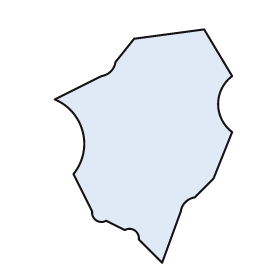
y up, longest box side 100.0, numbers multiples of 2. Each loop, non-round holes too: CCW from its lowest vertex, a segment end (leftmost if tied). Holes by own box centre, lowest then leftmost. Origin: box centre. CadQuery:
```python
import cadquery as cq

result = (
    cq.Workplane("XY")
    .moveTo(8.0, -50.0)
    .lineTo(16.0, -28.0)
    .threePointArc((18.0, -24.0), (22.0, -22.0))
    .lineTo(30.0, -14.0)
    .lineTo(38.0, 6.0)
    .threePointArc((32.0, 18.0), (38.0, 30.0))
    .lineTo(26.0, 50.0)
    .lineTo(-4.0, 46.0)
    .lineTo(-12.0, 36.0)
    .threePointArc((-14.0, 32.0), (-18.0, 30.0))
    .lineTo(-38.0, 20.0)
    .threePointArc((-26.0, 6.0), (-30.0, -12.0))
    .lineTo(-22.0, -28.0)
    .threePointArc((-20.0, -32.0), (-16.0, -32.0))
    .lineTo(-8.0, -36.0)
    .threePointArc((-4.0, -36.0), (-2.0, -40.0))
    .close()
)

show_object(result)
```